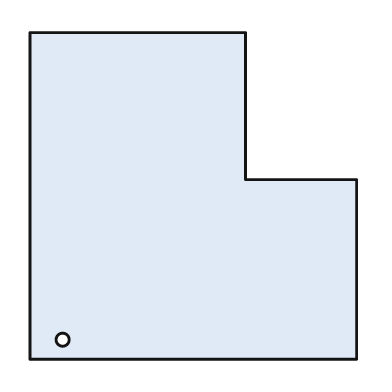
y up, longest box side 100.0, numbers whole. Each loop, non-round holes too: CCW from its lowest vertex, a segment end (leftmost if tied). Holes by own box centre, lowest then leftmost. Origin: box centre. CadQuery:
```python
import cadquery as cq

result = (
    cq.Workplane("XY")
    .moveTo(-50.0, -50.0)
    .lineTo(50.0, -50.0)
    .lineTo(50.0, 5.0)
    .lineTo(16.0, 5.0)
    .lineTo(16.0, 50.0)
    .lineTo(-50.0, 50.0)
    .close()
    .moveTo(-40.0, -44.0)
    .circle(2.0)
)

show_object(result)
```